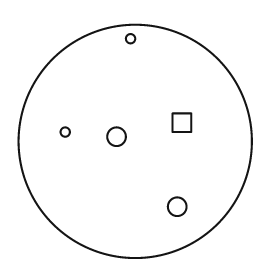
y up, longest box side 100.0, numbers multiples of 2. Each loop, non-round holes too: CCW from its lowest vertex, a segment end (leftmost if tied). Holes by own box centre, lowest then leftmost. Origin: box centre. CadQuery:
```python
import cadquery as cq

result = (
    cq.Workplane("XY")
    .moveTo(0.0, 0.0)
    .circle(50.0)
    .moveTo(18.0, -28.0)
    .circle(4.0)
    .moveTo(-8.0, 2.0)
    .circle(4.0)
    .moveTo(-30.0, 4.0)
    .circle(2.0)
    .moveTo(16.0, 4.0)
    .lineTo(24.0, 4.0)
    .lineTo(24.0, 12.0)
    .lineTo(16.0, 12.0)
    .close()
    .moveTo(-2.0, 44.0)
    .circle(2.0)
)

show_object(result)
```